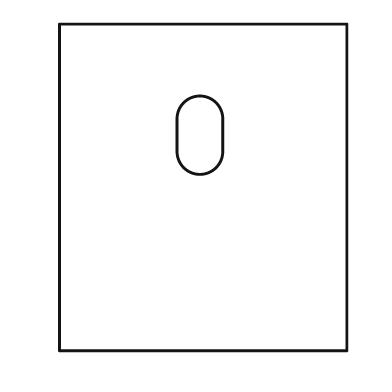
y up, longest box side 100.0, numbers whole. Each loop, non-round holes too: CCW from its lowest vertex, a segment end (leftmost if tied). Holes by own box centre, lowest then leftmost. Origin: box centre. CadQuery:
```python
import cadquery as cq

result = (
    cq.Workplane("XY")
    .moveTo(-44.0, -50.0)
    .lineTo(44.0, -50.0)
    .lineTo(44.0, 50.0)
    .lineTo(-44.0, 50.0)
    .close()
    .moveTo(-8.0, 11.0)
    .threePointArc((-1.0, 4.0), (6.0, 11.0))
    .lineTo(6.0, 21.0)
    .threePointArc((-1.0, 28.0), (-8.0, 21.0))
    .close()
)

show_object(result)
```